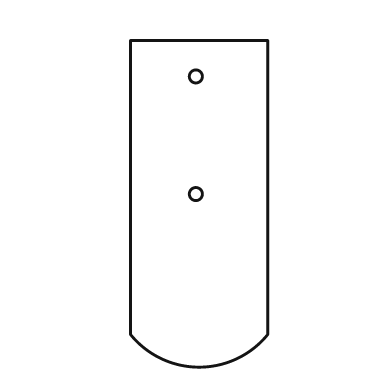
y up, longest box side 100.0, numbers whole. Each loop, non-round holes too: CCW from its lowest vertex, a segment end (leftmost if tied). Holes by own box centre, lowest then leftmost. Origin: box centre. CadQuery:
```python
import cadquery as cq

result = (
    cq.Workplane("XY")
    .moveTo(-21.0, -40.0)
    .threePointArc((0.0, -50.0), (21.0, -40.0))
    .lineTo(21.0, 50.0)
    .lineTo(-21.0, 50.0)
    .close()
    .moveTo(-1.0, 3.0)
    .circle(2.0)
    .moveTo(-1.0, 39.0)
    .circle(2.0)
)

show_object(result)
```